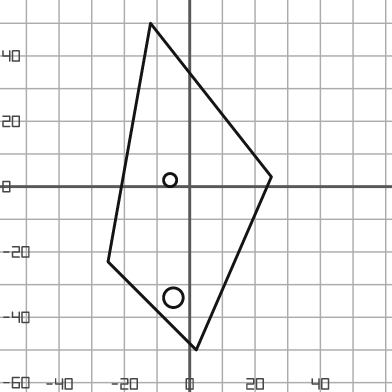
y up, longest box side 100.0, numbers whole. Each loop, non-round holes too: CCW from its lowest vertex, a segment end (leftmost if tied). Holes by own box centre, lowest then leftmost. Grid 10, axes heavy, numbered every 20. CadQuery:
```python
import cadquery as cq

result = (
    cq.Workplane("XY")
    .moveTo(2.0, -50.0)
    .lineTo(25.0, 3.0)
    .lineTo(-12.0, 50.0)
    .lineTo(-25.0, -23.0)
    .close()
    .moveTo(-5.0, -34.0)
    .circle(3.0)
    .moveTo(-6.0, 2.0)
    .circle(2.0)
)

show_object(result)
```